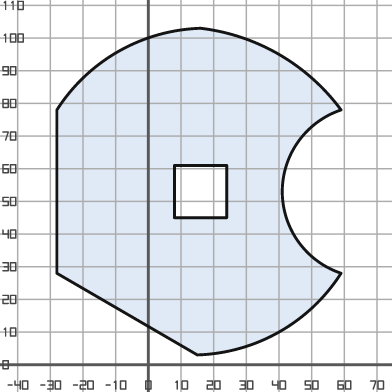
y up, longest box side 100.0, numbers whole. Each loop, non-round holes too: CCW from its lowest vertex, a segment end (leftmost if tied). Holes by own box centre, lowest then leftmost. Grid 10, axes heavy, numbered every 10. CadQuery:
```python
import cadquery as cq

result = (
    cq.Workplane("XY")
    .moveTo(15.0, 3.0)
    .threePointArc((40.0, 10.0), (59.0, 28.0))
    .threePointArc((41.0, 53.0), (59.0, 78.0))
    .threePointArc((40.0, 95.0), (16.0, 103.0))
    .threePointArc((-9.0, 96.0), (-28.0, 78.0))
    .lineTo(-28.0, 28.0)
    .close()
    .moveTo(8.0, 45.0)
    .lineTo(24.0, 45.0)
    .lineTo(24.0, 61.0)
    .lineTo(8.0, 61.0)
    .close()
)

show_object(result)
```